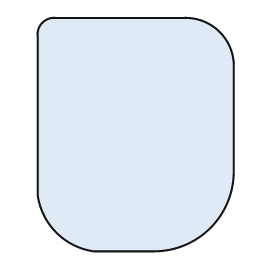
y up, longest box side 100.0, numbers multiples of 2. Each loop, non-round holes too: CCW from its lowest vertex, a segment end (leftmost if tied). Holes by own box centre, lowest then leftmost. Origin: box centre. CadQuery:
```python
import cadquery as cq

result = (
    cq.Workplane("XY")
    .moveTo(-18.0, -50.0)
    .lineTo(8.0, -50.0)
    .threePointArc((32.0, -40.0), (42.0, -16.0))
    .lineTo(42.0, 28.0)
    .threePointArc((36.0, 44.0), (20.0, 50.0))
    .lineTo(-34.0, 50.0)
    .threePointArc((-40.0, 48.0), (-42.0, 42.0))
    .lineTo(-42.0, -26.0)
    .threePointArc((-34.0, -42.0), (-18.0, -50.0))
    .close()
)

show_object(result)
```